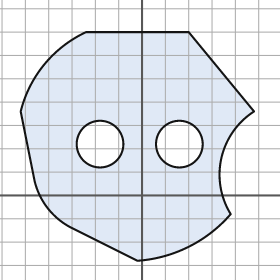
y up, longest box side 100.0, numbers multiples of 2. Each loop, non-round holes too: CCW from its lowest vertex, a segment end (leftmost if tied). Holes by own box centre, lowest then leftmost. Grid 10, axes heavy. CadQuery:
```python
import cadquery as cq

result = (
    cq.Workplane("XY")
    .moveTo(-2.0, -28.0)
    .threePointArc((20.0, -22.0), (38.0, -8.0))
    .threePointArc((34.0, 16.0), (48.0, 36.0))
    .lineTo(20.0, 70.0)
    .lineTo(-24.0, 70.0)
    .threePointArc((-42.0, 56.0), (-52.0, 36.0))
    .lineTo(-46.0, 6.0)
    .threePointArc((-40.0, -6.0), (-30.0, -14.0))
    .close()
    .moveTo(-18.0, 22.0)
    .circle(10.0)
    .moveTo(16.0, 22.0)
    .circle(10.0)
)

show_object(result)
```